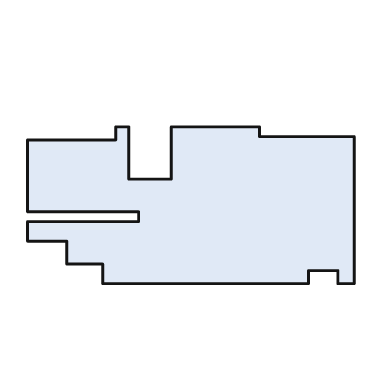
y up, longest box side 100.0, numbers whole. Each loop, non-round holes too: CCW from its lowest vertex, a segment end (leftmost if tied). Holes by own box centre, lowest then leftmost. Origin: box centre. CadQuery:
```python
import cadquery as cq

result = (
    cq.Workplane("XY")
    .moveTo(-27.0, -24.0)
    .lineTo(36.0, -24.0)
    .lineTo(36.0, -20.0)
    .lineTo(45.0, -20.0)
    .lineTo(45.0, -24.0)
    .lineTo(50.0, -24.0)
    .lineTo(50.0, 21.0)
    .lineTo(21.0, 21.0)
    .lineTo(21.0, 24.0)
    .lineTo(-6.0, 24.0)
    .lineTo(-6.0, 8.0)
    .lineTo(-19.0, 8.0)
    .lineTo(-19.0, 24.0)
    .lineTo(-23.0, 24.0)
    .lineTo(-23.0, 20.0)
    .lineTo(-50.0, 20.0)
    .lineTo(-50.0, -2.0)
    .lineTo(-16.0, -2.0)
    .lineTo(-16.0, -5.0)
    .lineTo(-50.0, -5.0)
    .lineTo(-50.0, -11.0)
    .lineTo(-38.0, -11.0)
    .lineTo(-38.0, -18.0)
    .lineTo(-27.0, -18.0)
    .close()
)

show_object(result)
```